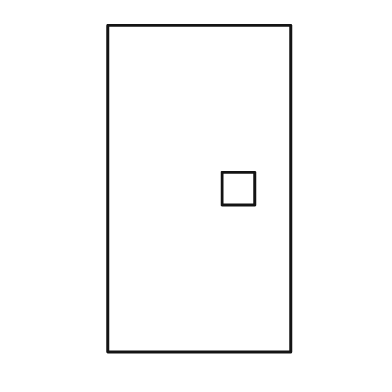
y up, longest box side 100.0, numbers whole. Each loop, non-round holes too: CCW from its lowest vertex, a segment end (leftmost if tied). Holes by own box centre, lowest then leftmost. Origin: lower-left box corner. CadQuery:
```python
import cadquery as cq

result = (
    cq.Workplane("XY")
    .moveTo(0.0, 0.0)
    .lineTo(56.0, 0.0)
    .lineTo(56.0, 100.0)
    .lineTo(0.0, 100.0)
    .close()
    .moveTo(35.0, 45.0)
    .lineTo(45.0, 45.0)
    .lineTo(45.0, 55.0)
    .lineTo(35.0, 55.0)
    .close()
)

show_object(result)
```